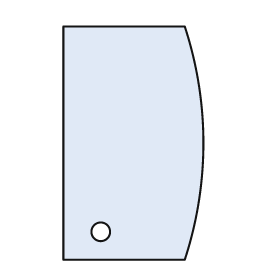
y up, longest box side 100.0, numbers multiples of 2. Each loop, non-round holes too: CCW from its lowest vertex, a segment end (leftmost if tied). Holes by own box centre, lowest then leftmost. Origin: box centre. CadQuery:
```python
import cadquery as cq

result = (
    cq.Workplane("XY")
    .moveTo(-30.0, -50.0)
    .lineTo(22.0, -50.0)
    .threePointArc((30.0, 0.0), (22.0, 50.0))
    .lineTo(-30.0, 50.0)
    .close()
    .moveTo(-14.0, -38.0)
    .circle(4.0)
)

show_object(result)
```